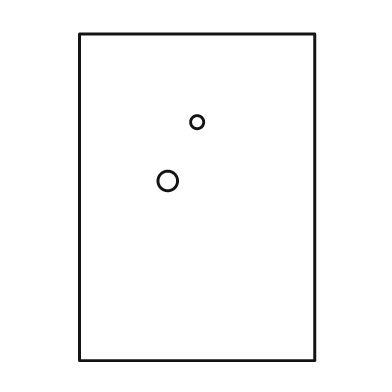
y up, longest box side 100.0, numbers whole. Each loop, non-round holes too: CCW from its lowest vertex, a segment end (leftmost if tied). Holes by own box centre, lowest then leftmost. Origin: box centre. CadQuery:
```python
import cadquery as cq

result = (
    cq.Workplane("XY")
    .moveTo(-36.0, -50.0)
    .lineTo(36.0, -50.0)
    .lineTo(36.0, 50.0)
    .lineTo(-36.0, 50.0)
    .close()
    .moveTo(-9.0, 5.0)
    .circle(3.0)
    .moveTo(0.0, 23.0)
    .circle(2.0)
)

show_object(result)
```